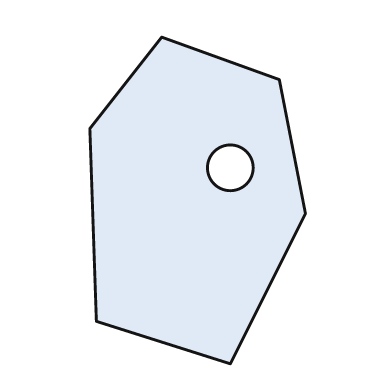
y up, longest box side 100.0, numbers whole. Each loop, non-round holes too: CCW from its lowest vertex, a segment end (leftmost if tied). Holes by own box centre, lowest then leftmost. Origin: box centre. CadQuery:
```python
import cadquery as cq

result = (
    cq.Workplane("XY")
    .moveTo(10.0, -50.0)
    .lineTo(33.0, -4.0)
    .lineTo(25.0, 37.0)
    .lineTo(-11.0, 50.0)
    .lineTo(-33.0, 22.0)
    .lineTo(-31.0, -37.0)
    .close()
    .moveTo(10.0, 10.0)
    .circle(7.0)
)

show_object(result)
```